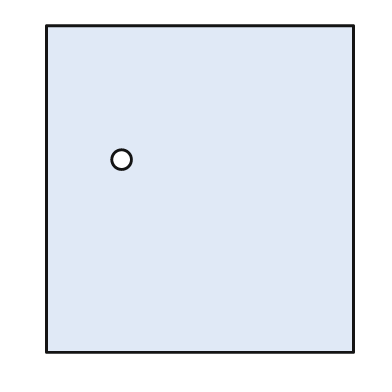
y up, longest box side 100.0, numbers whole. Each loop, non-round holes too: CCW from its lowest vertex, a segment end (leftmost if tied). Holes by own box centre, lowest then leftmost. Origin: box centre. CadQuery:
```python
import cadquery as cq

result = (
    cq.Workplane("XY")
    .moveTo(-47.0, -50.0)
    .lineTo(47.0, -50.0)
    .lineTo(47.0, 50.0)
    .lineTo(-47.0, 50.0)
    .close()
    .moveTo(-24.0, 9.0)
    .circle(3.0)
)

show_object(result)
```